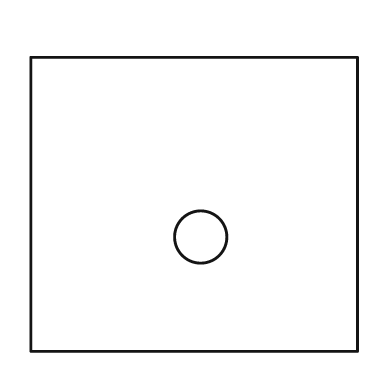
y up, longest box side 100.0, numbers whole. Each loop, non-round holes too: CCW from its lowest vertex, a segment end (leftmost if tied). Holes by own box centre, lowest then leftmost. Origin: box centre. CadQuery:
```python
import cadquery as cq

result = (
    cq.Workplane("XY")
    .moveTo(-50.0, -45.0)
    .lineTo(50.0, -45.0)
    .lineTo(50.0, 45.0)
    .lineTo(-50.0, 45.0)
    .close()
    .moveTo(2.0, -10.0)
    .circle(8.0)
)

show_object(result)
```